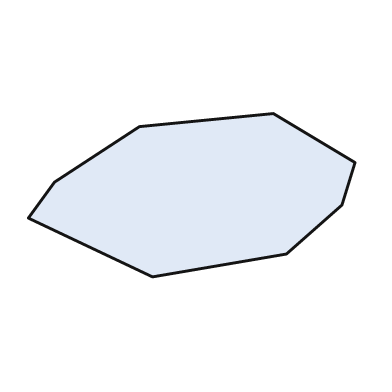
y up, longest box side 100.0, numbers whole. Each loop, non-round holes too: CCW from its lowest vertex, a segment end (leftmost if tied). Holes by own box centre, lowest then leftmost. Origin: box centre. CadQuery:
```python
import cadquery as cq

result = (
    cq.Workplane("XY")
    .moveTo(-12.0, -25.0)
    .lineTo(29.0, -18.0)
    .lineTo(46.0, -3.0)
    .lineTo(50.0, 10.0)
    .lineTo(25.0, 25.0)
    .lineTo(-16.0, 21.0)
    .lineTo(-42.0, 4.0)
    .lineTo(-50.0, -7.0)
    .close()
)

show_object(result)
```